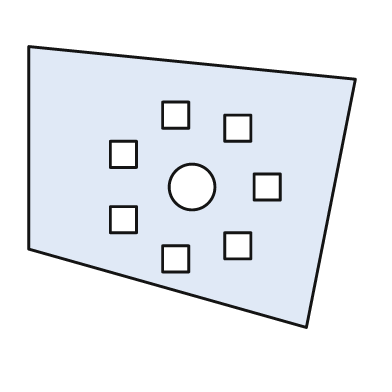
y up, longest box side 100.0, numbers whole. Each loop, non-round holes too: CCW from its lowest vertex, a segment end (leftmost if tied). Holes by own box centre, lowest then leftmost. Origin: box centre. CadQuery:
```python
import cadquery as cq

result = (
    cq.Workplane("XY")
    .moveTo(35.0, -43.0)
    .lineTo(50.0, 33.0)
    .lineTo(-50.0, 43.0)
    .lineTo(-50.0, -19.0)
    .close()
    .moveTo(-9.0, -26.0)
    .lineTo(-1.0, -26.0)
    .lineTo(-1.0, -18.0)
    .lineTo(-9.0, -18.0)
    .close()
    .moveTo(10.0, -22.0)
    .lineTo(18.0, -22.0)
    .lineTo(18.0, -14.0)
    .lineTo(10.0, -14.0)
    .close()
    .moveTo(-25.0, -14.0)
    .lineTo(-17.0, -14.0)
    .lineTo(-17.0, -6.0)
    .lineTo(-25.0, -6.0)
    .close()
    .moveTo(0.0, 0.0)
    .circle(7.0)
    .moveTo(19.0, -4.0)
    .lineTo(27.0, -4.0)
    .lineTo(27.0, 4.0)
    .lineTo(19.0, 4.0)
    .close()
    .moveTo(-25.0, 6.0)
    .lineTo(-17.0, 6.0)
    .lineTo(-17.0, 14.0)
    .lineTo(-25.0, 14.0)
    .close()
    .moveTo(10.0, 14.0)
    .lineTo(18.0, 14.0)
    .lineTo(18.0, 22.0)
    .lineTo(10.0, 22.0)
    .close()
    .moveTo(-9.0, 18.0)
    .lineTo(-1.0, 18.0)
    .lineTo(-1.0, 26.0)
    .lineTo(-9.0, 26.0)
    .close()
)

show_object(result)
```